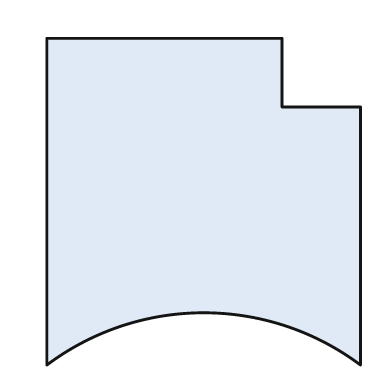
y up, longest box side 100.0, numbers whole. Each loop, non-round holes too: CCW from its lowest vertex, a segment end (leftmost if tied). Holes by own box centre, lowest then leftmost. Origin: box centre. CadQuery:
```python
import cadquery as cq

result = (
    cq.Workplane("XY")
    .moveTo(-48.0, -50.0)
    .threePointArc((0.0, -34.0), (48.0, -50.0))
    .lineTo(48.0, 29.0)
    .lineTo(24.0, 29.0)
    .lineTo(24.0, 50.0)
    .lineTo(-48.0, 50.0)
    .close()
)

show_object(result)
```